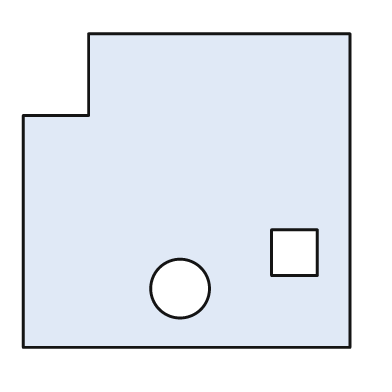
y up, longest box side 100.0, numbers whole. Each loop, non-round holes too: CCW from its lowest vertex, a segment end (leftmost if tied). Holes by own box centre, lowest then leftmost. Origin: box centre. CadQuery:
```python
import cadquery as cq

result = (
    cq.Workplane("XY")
    .moveTo(-50.0, -48.0)
    .lineTo(50.0, -48.0)
    .lineTo(50.0, 48.0)
    .lineTo(-30.0, 48.0)
    .lineTo(-30.0, 23.0)
    .lineTo(-50.0, 23.0)
    .close()
    .moveTo(-2.0, -30.0)
    .circle(9.0)
    .moveTo(26.0, -26.0)
    .lineTo(40.0, -26.0)
    .lineTo(40.0, -12.0)
    .lineTo(26.0, -12.0)
    .close()
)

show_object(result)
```